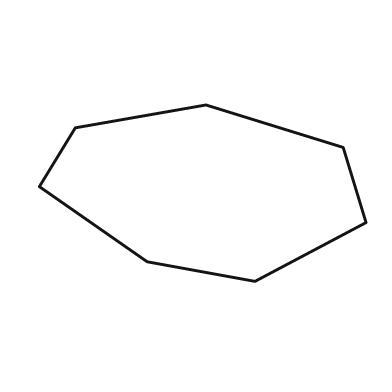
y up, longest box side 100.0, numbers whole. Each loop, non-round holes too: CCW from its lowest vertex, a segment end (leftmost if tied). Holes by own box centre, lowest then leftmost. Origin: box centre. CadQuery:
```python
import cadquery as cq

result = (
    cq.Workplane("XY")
    .moveTo(16.0, -27.0)
    .lineTo(50.0, -9.0)
    .lineTo(43.0, 14.0)
    .lineTo(1.0, 27.0)
    .lineTo(-39.0, 20.0)
    .lineTo(-50.0, 2.0)
    .lineTo(-17.0, -21.0)
    .close()
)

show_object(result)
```